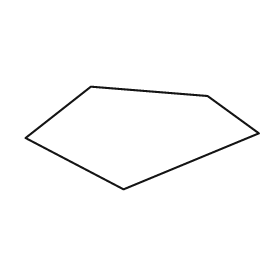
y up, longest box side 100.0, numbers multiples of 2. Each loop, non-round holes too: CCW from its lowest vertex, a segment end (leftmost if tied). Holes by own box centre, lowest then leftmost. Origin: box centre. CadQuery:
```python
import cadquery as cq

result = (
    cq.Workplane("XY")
    .moveTo(-8.0, -22.0)
    .lineTo(50.0, 2.0)
    .lineTo(28.0, 18.0)
    .lineTo(-22.0, 22.0)
    .lineTo(-50.0, 0.0)
    .close()
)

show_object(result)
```